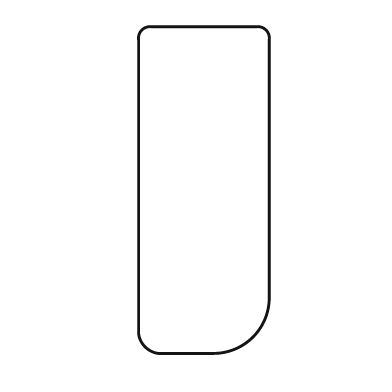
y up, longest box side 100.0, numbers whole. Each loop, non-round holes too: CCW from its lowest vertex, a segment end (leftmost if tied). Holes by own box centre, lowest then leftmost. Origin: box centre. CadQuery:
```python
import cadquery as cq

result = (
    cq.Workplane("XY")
    .moveTo(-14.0, -50.0)
    .lineTo(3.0, -50.0)
    .threePointArc((15.0, -45.0), (20.0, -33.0))
    .lineTo(20.0, 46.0)
    .threePointArc((19.0, 49.0), (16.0, 50.0))
    .lineTo(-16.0, 50.0)
    .threePointArc((-19.0, 49.0), (-20.0, 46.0))
    .lineTo(-20.0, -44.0)
    .threePointArc((-18.0, -48.0), (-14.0, -50.0))
    .close()
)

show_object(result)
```